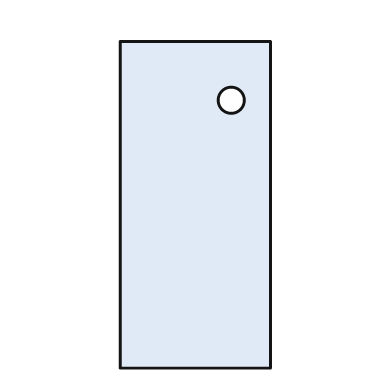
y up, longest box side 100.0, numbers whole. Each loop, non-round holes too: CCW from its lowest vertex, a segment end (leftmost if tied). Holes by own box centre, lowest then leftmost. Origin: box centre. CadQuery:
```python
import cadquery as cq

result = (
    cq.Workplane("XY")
    .moveTo(-23.0, -50.0)
    .lineTo(23.0, -50.0)
    .lineTo(23.0, 50.0)
    .lineTo(-23.0, 50.0)
    .close()
    .moveTo(11.0, 32.0)
    .circle(4.0)
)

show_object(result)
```